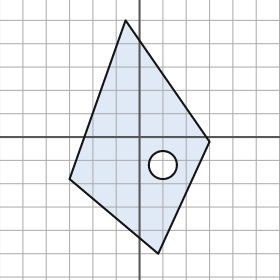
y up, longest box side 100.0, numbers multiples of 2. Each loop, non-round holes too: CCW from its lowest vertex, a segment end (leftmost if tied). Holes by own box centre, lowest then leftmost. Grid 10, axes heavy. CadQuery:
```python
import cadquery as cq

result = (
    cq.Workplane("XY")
    .moveTo(8.0, -50.0)
    .lineTo(30.0, -2.0)
    .lineTo(-6.0, 50.0)
    .lineTo(-30.0, -18.0)
    .close()
    .moveTo(10.0, -12.0)
    .circle(6.0)
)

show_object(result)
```